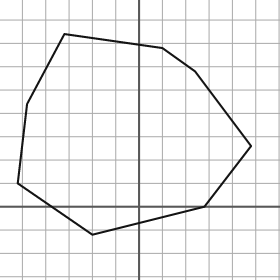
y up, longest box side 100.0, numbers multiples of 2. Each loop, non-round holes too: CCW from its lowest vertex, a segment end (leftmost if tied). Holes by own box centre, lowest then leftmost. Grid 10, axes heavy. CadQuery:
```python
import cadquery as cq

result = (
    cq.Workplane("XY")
    .moveTo(-20.0, -12.0)
    .lineTo(28.0, 0.0)
    .lineTo(48.0, 26.0)
    .lineTo(24.0, 58.0)
    .lineTo(10.0, 68.0)
    .lineTo(-32.0, 74.0)
    .lineTo(-48.0, 44.0)
    .lineTo(-52.0, 10.0)
    .close()
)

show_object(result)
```